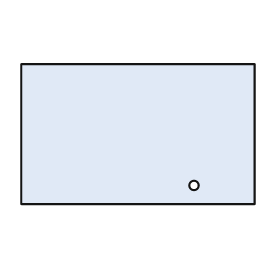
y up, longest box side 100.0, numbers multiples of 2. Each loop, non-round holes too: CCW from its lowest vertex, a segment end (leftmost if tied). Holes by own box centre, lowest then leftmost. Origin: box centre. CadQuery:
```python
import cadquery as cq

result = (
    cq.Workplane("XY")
    .moveTo(-50.0, -30.0)
    .lineTo(50.0, -30.0)
    .lineTo(50.0, 30.0)
    .lineTo(-50.0, 30.0)
    .close()
    .moveTo(24.0, -22.0)
    .circle(2.0)
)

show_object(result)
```